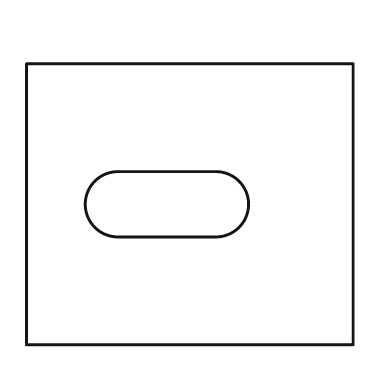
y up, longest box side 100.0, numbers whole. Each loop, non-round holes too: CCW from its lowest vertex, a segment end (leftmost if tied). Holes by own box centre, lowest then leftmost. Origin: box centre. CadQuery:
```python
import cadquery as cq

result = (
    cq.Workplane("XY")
    .moveTo(-50.0, -43.0)
    .lineTo(50.0, -43.0)
    .lineTo(50.0, 43.0)
    .lineTo(-50.0, 43.0)
    .close()
    .moveTo(-22.0, -10.0)
    .lineTo(8.0, -10.0)
    .threePointArc((18.0, 0.0), (8.0, 10.0))
    .lineTo(-22.0, 10.0)
    .threePointArc((-32.0, 0.0), (-22.0, -10.0))
    .close()
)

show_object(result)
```